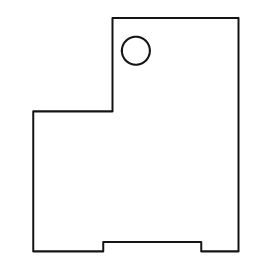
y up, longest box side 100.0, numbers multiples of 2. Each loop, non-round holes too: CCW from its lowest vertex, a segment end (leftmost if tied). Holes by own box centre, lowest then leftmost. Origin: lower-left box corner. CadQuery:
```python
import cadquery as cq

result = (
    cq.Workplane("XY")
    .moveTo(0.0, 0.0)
    .lineTo(30.0, 0.0)
    .lineTo(30.0, 4.0)
    .lineTo(72.0, 4.0)
    .lineTo(72.0, 0.0)
    .lineTo(88.0, 0.0)
    .lineTo(88.0, 100.0)
    .lineTo(34.0, 100.0)
    .lineTo(34.0, 60.0)
    .lineTo(0.0, 60.0)
    .close()
    .moveTo(44.0, 86.0)
    .circle(6.0)
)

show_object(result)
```